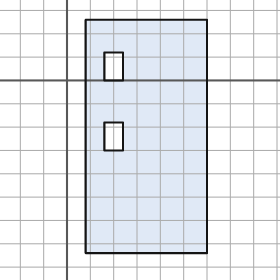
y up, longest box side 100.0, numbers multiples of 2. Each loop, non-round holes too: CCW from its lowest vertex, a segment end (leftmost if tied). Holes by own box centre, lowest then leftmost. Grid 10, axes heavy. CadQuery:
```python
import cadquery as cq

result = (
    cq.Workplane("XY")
    .moveTo(8.0, -74.0)
    .lineTo(60.0, -74.0)
    .lineTo(60.0, 26.0)
    .lineTo(8.0, 26.0)
    .close()
    .moveTo(16.0, -30.0)
    .lineTo(24.0, -30.0)
    .lineTo(24.0, -18.0)
    .lineTo(16.0, -18.0)
    .close()
    .moveTo(16.0, 0.0)
    .lineTo(24.0, 0.0)
    .lineTo(24.0, 12.0)
    .lineTo(16.0, 12.0)
    .close()
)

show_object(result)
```